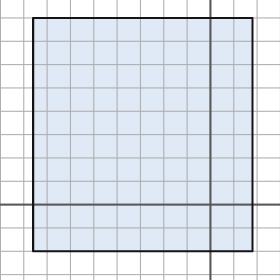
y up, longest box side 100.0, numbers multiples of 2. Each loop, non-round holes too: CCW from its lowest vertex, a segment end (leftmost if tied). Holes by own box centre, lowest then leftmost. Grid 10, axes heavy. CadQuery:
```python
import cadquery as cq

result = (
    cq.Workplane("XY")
    .moveTo(-76.0, -20.0)
    .lineTo(18.0, -20.0)
    .lineTo(18.0, 80.0)
    .lineTo(-76.0, 80.0)
    .close()
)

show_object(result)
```